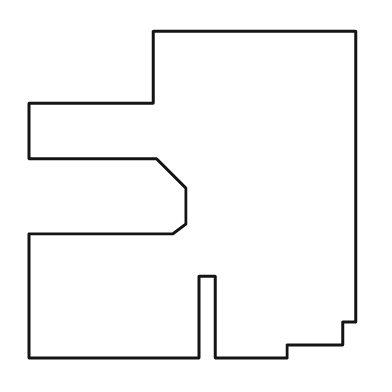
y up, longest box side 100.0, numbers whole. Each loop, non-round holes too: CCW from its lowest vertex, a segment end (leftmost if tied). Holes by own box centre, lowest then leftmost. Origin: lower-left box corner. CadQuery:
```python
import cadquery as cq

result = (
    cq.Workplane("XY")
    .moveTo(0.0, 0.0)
    .lineTo(52.0, 0.0)
    .lineTo(52.0, 25.0)
    .lineTo(57.0, 25.0)
    .lineTo(57.0, 0.0)
    .lineTo(79.0, 0.0)
    .lineTo(79.0, 4.0)
    .lineTo(96.0, 4.0)
    .lineTo(96.0, 11.0)
    .lineTo(100.0, 11.0)
    .lineTo(100.0, 100.0)
    .lineTo(38.0, 100.0)
    .lineTo(38.0, 78.0)
    .lineTo(0.0, 78.0)
    .lineTo(0.0, 61.0)
    .lineTo(39.0, 61.0)
    .lineTo(48.0, 52.0)
    .lineTo(48.0, 41.0)
    .lineTo(44.0, 38.0)
    .lineTo(0.0, 38.0)
    .close()
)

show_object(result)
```